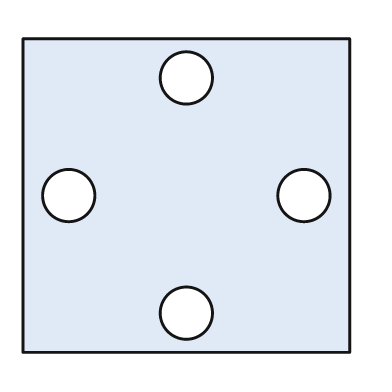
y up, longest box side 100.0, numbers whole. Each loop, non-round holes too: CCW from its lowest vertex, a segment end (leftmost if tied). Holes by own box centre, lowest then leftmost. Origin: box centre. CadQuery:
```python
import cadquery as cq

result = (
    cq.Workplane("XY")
    .moveTo(-50.0, -48.0)
    .lineTo(50.0, -48.0)
    .lineTo(50.0, 48.0)
    .lineTo(-50.0, 48.0)
    .close()
    .moveTo(0.0, -36.0)
    .circle(8.0)
    .moveTo(-36.0, 0.0)
    .circle(8.0)
    .moveTo(36.0, 0.0)
    .circle(8.0)
    .moveTo(0.0, 36.0)
    .circle(8.0)
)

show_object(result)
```